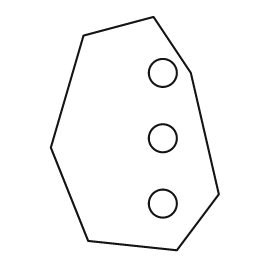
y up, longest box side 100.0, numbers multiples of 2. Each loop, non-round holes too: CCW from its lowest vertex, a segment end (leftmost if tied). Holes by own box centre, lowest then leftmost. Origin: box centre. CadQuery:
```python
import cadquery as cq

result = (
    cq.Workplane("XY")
    .moveTo(18.0, -50.0)
    .lineTo(36.0, -26.0)
    .lineTo(24.0, 26.0)
    .lineTo(8.0, 50.0)
    .lineTo(-22.0, 42.0)
    .lineTo(-36.0, -6.0)
    .lineTo(-20.0, -46.0)
    .close()
    .moveTo(12.0, -30.0)
    .circle(6.0)
    .moveTo(12.0, -2.0)
    .circle(6.0)
    .moveTo(12.0, 26.0)
    .circle(6.0)
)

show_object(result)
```